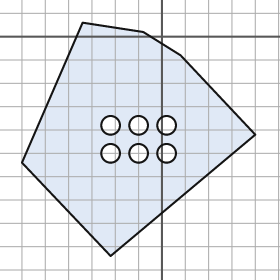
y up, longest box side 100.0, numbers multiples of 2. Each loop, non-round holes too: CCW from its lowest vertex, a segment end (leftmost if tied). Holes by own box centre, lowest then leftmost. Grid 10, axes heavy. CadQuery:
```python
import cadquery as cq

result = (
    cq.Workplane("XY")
    .moveTo(-22.0, -94.0)
    .lineTo(40.0, -42.0)
    .lineTo(8.0, -8.0)
    .lineTo(-8.0, 2.0)
    .lineTo(-34.0, 6.0)
    .lineTo(-60.0, -54.0)
    .close()
    .moveTo(-22.0, -50.0)
    .circle(4.0)
    .moveTo(-10.0, -50.0)
    .circle(4.0)
    .moveTo(2.0, -50.0)
    .circle(4.0)
    .moveTo(-22.0, -38.0)
    .circle(4.0)
    .moveTo(-10.0, -38.0)
    .circle(4.0)
    .moveTo(2.0, -38.0)
    .circle(4.0)
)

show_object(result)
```